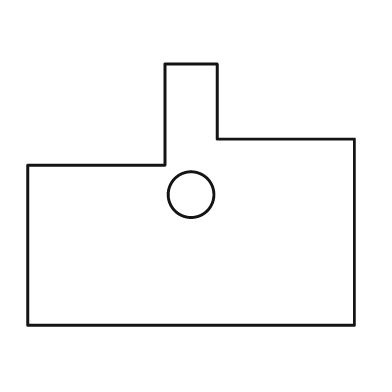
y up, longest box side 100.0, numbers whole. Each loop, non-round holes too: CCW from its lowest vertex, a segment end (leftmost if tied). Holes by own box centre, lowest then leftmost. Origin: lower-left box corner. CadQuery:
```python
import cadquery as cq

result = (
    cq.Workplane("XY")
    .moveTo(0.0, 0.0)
    .lineTo(100.0, 0.0)
    .lineTo(100.0, 57.0)
    .lineTo(58.0, 57.0)
    .lineTo(58.0, 80.0)
    .lineTo(42.0, 80.0)
    .lineTo(42.0, 49.0)
    .lineTo(0.0, 49.0)
    .close()
    .moveTo(50.0, 40.0)
    .circle(7.0)
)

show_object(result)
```